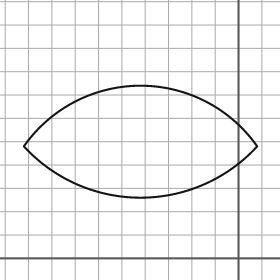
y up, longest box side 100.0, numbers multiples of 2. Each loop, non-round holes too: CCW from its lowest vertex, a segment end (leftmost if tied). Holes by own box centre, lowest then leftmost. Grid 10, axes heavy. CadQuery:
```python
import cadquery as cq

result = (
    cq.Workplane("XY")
    .moveTo(-92.0, 48.0)
    .threePointArc((-42.0, 26.0), (8.0, 48.0))
    .threePointArc((-42.0, 74.0), (-92.0, 48.0))
    .close()
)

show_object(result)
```